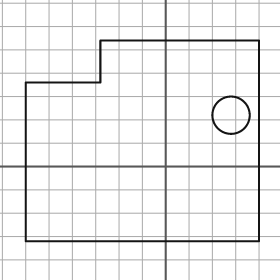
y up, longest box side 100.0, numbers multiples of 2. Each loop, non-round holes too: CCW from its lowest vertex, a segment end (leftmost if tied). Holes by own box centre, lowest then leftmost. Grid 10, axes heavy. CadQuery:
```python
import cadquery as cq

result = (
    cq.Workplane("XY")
    .moveTo(-60.0, -32.0)
    .lineTo(40.0, -32.0)
    .lineTo(40.0, 54.0)
    .lineTo(-28.0, 54.0)
    .lineTo(-28.0, 36.0)
    .lineTo(-60.0, 36.0)
    .close()
    .moveTo(28.0, 22.0)
    .circle(8.0)
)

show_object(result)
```